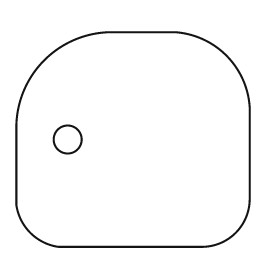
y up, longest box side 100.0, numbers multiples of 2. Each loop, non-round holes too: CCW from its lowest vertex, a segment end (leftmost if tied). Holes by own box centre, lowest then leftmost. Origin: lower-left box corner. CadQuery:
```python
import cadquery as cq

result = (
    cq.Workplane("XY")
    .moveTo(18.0, 0.0)
    .lineTo(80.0, 0.0)
    .threePointArc((94.0, 6.0), (100.0, 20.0))
    .lineTo(100.0, 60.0)
    .threePointArc((90.0, 82.0), (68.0, 92.0))
    .lineTo(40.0, 92.0)
    .threePointArc((12.0, 80.0), (0.0, 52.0))
    .lineTo(0.0, 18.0)
    .threePointArc((6.0, 6.0), (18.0, 0.0))
    .close()
    .moveTo(22.0, 46.0)
    .circle(6.0)
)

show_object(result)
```